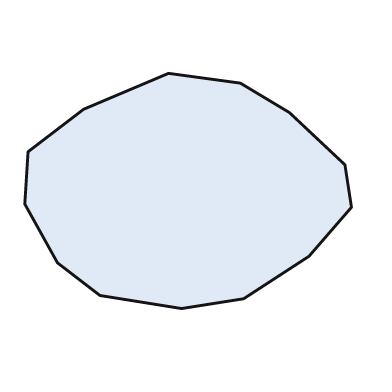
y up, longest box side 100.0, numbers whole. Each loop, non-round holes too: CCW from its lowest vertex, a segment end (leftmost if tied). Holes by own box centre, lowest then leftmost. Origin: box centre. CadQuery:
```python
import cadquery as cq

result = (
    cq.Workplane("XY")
    .moveTo(-2.0, -36.0)
    .lineTo(17.0, -33.0)
    .lineTo(37.0, -20.0)
    .lineTo(50.0, -5.0)
    .lineTo(48.0, 8.0)
    .lineTo(31.0, 24.0)
    .lineTo(16.0, 33.0)
    .lineTo(-6.0, 36.0)
    .lineTo(-32.0, 25.0)
    .lineTo(-49.0, 12.0)
    .lineTo(-50.0, -4.0)
    .lineTo(-40.0, -22.0)
    .lineTo(-27.0, -32.0)
    .close()
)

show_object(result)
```